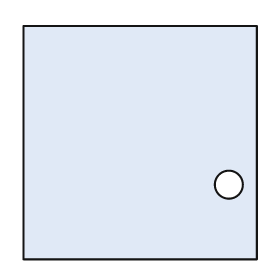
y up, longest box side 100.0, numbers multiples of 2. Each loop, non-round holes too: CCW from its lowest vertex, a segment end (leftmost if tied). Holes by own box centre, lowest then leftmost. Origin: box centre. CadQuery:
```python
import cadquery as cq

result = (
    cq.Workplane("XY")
    .moveTo(-50.0, -50.0)
    .lineTo(50.0, -50.0)
    .lineTo(50.0, 50.0)
    .lineTo(-50.0, 50.0)
    .close()
    .moveTo(38.0, -18.0)
    .circle(6.0)
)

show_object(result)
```